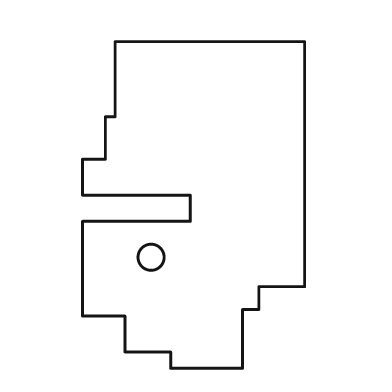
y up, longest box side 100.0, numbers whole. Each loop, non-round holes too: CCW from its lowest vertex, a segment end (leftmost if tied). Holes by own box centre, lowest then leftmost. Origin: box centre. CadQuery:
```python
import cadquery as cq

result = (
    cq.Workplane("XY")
    .moveTo(-7.0, -50.0)
    .lineTo(15.0, -50.0)
    .lineTo(15.0, -32.0)
    .lineTo(20.0, -32.0)
    .lineTo(20.0, -25.0)
    .lineTo(34.0, -25.0)
    .lineTo(34.0, 50.0)
    .lineTo(-24.0, 50.0)
    .lineTo(-24.0, 27.0)
    .lineTo(-27.0, 27.0)
    .lineTo(-27.0, 14.0)
    .lineTo(-34.0, 14.0)
    .lineTo(-34.0, 3.0)
    .lineTo(-1.0, 3.0)
    .lineTo(-1.0, -5.0)
    .lineTo(-34.0, -5.0)
    .lineTo(-34.0, -34.0)
    .lineTo(-21.0, -34.0)
    .lineTo(-21.0, -45.0)
    .lineTo(-7.0, -45.0)
    .close()
    .moveTo(-13.0, -16.0)
    .circle(4.0)
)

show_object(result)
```